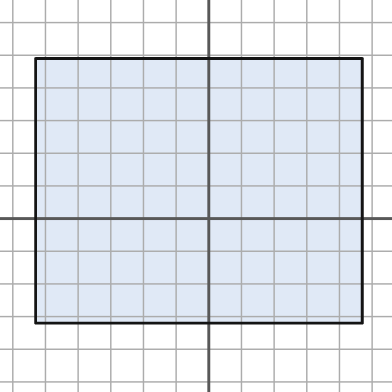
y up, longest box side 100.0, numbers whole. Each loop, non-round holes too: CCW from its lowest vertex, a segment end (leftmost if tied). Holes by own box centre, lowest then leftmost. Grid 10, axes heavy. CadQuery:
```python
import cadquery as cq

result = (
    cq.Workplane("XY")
    .moveTo(-53.0, -32.0)
    .lineTo(47.0, -32.0)
    .lineTo(47.0, 49.0)
    .lineTo(-53.0, 49.0)
    .close()
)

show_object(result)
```